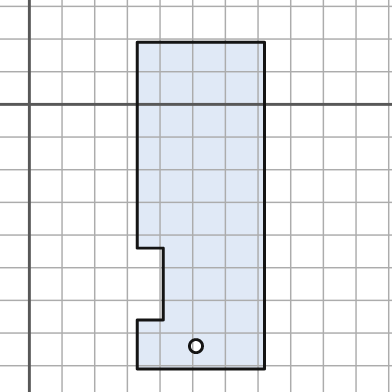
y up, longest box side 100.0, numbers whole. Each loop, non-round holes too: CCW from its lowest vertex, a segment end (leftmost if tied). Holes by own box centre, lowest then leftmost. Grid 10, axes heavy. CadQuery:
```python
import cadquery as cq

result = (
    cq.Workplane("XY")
    .moveTo(33.0, -81.0)
    .lineTo(72.0, -81.0)
    .lineTo(72.0, 19.0)
    .lineTo(33.0, 19.0)
    .lineTo(33.0, -44.0)
    .lineTo(41.0, -44.0)
    .lineTo(41.0, -66.0)
    .lineTo(33.0, -66.0)
    .close()
    .moveTo(51.0, -74.0)
    .circle(2.0)
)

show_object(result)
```